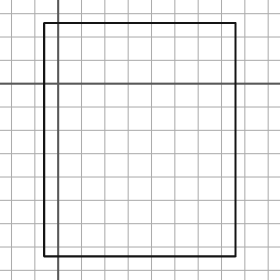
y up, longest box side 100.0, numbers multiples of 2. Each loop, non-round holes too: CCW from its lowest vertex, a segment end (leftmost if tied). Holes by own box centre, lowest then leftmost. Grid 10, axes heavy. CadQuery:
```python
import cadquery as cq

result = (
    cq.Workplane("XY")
    .moveTo(-6.0, -74.0)
    .lineTo(76.0, -74.0)
    .lineTo(76.0, 26.0)
    .lineTo(-6.0, 26.0)
    .close()
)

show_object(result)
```